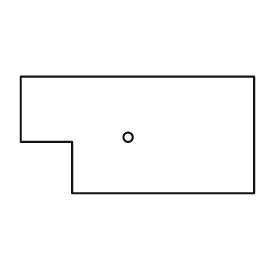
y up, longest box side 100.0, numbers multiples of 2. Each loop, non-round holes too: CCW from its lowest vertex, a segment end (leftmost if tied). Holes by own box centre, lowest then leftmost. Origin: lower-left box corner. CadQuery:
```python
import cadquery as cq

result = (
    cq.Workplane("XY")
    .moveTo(22.0, 0.0)
    .lineTo(100.0, 0.0)
    .lineTo(100.0, 50.0)
    .lineTo(0.0, 50.0)
    .lineTo(0.0, 22.0)
    .lineTo(22.0, 22.0)
    .close()
    .moveTo(46.0, 24.0)
    .circle(2.0)
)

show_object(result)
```